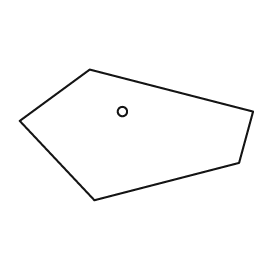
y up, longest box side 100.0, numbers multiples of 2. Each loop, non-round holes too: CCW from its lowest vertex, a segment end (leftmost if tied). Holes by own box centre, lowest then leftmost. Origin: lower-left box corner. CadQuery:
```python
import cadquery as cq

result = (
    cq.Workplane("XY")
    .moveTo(32.0, 0.0)
    .lineTo(94.0, 16.0)
    .lineTo(100.0, 38.0)
    .lineTo(30.0, 56.0)
    .lineTo(0.0, 34.0)
    .close()
    .moveTo(44.0, 38.0)
    .circle(2.0)
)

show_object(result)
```